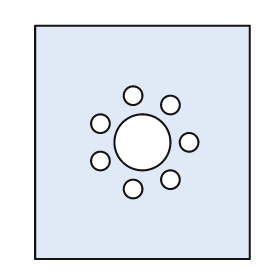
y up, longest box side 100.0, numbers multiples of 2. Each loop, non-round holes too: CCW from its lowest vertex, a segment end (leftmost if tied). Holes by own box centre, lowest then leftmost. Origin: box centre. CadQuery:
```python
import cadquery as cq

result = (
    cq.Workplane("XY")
    .moveTo(-46.0, -50.0)
    .lineTo(46.0, -50.0)
    .lineTo(46.0, 50.0)
    .lineTo(-46.0, 50.0)
    .close()
    .moveTo(-4.0, -20.0)
    .circle(4.0)
    .moveTo(12.0, -16.0)
    .circle(4.0)
    .moveTo(-18.0, -8.0)
    .circle(4.0)
    .moveTo(0.0, 0.0)
    .circle(12.0)
    .moveTo(20.0, 0.0)
    .circle(4.0)
    .moveTo(-18.0, 8.0)
    .circle(4.0)
    .moveTo(12.0, 16.0)
    .circle(4.0)
    .moveTo(-4.0, 20.0)
    .circle(4.0)
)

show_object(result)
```